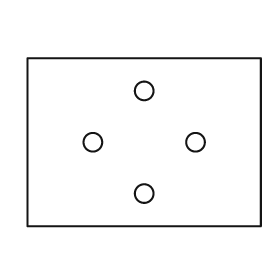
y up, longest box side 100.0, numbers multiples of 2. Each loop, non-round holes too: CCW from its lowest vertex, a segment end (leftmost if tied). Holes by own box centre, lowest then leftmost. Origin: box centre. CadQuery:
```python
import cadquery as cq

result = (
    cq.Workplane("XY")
    .moveTo(-50.0, -36.0)
    .lineTo(50.0, -36.0)
    .lineTo(50.0, 36.0)
    .lineTo(-50.0, 36.0)
    .close()
    .moveTo(0.0, -22.0)
    .circle(4.0)
    .moveTo(-22.0, 0.0)
    .circle(4.0)
    .moveTo(22.0, 0.0)
    .circle(4.0)
    .moveTo(0.0, 22.0)
    .circle(4.0)
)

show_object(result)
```